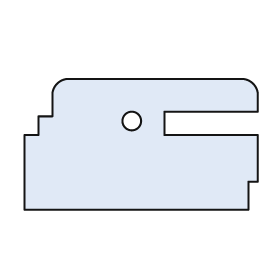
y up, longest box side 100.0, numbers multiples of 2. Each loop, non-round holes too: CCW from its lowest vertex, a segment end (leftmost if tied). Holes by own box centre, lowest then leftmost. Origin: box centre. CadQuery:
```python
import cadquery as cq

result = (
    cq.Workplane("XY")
    .moveTo(-50.0, -28.0)
    .lineTo(46.0, -28.0)
    .lineTo(46.0, -16.0)
    .lineTo(50.0, -16.0)
    .lineTo(50.0, 4.0)
    .lineTo(10.0, 4.0)
    .lineTo(10.0, 14.0)
    .lineTo(50.0, 14.0)
    .lineTo(50.0, 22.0)
    .threePointArc((48.0, 26.0), (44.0, 28.0))
    .lineTo(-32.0, 28.0)
    .threePointArc((-36.0, 26.0), (-38.0, 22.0))
    .lineTo(-38.0, 12.0)
    .lineTo(-44.0, 12.0)
    .lineTo(-44.0, 4.0)
    .lineTo(-50.0, 4.0)
    .close()
    .moveTo(-4.0, 10.0)
    .circle(4.0)
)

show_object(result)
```